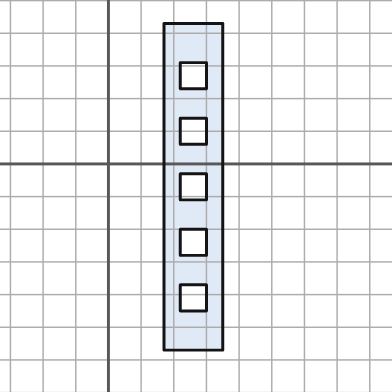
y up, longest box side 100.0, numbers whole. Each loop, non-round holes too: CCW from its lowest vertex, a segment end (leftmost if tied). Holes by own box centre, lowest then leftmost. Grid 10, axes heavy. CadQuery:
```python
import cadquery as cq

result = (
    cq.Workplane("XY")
    .moveTo(17.0, -57.0)
    .lineTo(35.0, -57.0)
    .lineTo(35.0, 43.0)
    .lineTo(17.0, 43.0)
    .close()
    .moveTo(22.0, -45.0)
    .lineTo(30.0, -45.0)
    .lineTo(30.0, -37.0)
    .lineTo(22.0, -37.0)
    .close()
    .moveTo(22.0, -28.0)
    .lineTo(30.0, -28.0)
    .lineTo(30.0, -20.0)
    .lineTo(22.0, -20.0)
    .close()
    .moveTo(22.0, -11.0)
    .lineTo(30.0, -11.0)
    .lineTo(30.0, -3.0)
    .lineTo(22.0, -3.0)
    .close()
    .moveTo(22.0, 6.0)
    .lineTo(30.0, 6.0)
    .lineTo(30.0, 14.0)
    .lineTo(22.0, 14.0)
    .close()
    .moveTo(22.0, 23.0)
    .lineTo(30.0, 23.0)
    .lineTo(30.0, 31.0)
    .lineTo(22.0, 31.0)
    .close()
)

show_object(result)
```